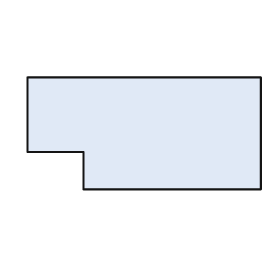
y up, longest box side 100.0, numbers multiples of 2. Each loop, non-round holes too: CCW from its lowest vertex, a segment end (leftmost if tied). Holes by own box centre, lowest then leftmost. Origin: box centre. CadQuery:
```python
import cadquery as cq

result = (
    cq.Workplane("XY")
    .moveTo(-26.0, -24.0)
    .lineTo(50.0, -24.0)
    .lineTo(50.0, 24.0)
    .lineTo(-50.0, 24.0)
    .lineTo(-50.0, -8.0)
    .lineTo(-26.0, -8.0)
    .close()
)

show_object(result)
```